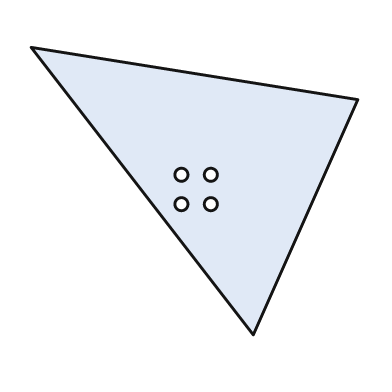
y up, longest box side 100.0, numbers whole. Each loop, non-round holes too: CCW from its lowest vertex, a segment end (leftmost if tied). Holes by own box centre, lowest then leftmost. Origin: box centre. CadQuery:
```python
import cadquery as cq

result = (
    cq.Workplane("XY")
    .moveTo(18.0, -44.0)
    .lineTo(50.0, 28.0)
    .lineTo(-50.0, 44.0)
    .close()
    .moveTo(-4.0, -4.0)
    .circle(2.0)
    .moveTo(5.0, -4.0)
    .circle(2.0)
    .moveTo(-4.0, 5.0)
    .circle(2.0)
    .moveTo(5.0, 5.0)
    .circle(2.0)
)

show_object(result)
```